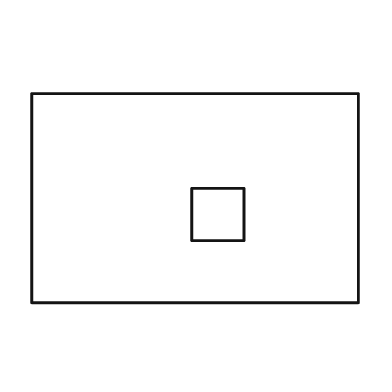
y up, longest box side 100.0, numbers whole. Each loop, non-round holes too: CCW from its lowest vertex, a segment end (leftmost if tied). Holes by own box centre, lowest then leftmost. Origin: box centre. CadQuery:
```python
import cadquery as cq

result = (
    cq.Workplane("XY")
    .moveTo(-50.0, -32.0)
    .lineTo(50.0, -32.0)
    .lineTo(50.0, 32.0)
    .lineTo(-50.0, 32.0)
    .close()
    .moveTo(-1.0, -13.0)
    .lineTo(15.0, -13.0)
    .lineTo(15.0, 3.0)
    .lineTo(-1.0, 3.0)
    .close()
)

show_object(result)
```